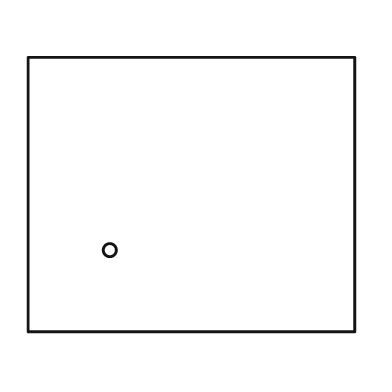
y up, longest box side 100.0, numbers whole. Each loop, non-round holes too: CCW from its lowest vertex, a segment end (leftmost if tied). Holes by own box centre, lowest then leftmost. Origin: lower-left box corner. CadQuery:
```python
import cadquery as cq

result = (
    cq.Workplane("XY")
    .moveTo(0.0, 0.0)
    .lineTo(100.0, 0.0)
    .lineTo(100.0, 84.0)
    .lineTo(0.0, 84.0)
    .close()
    .moveTo(25.0, 25.0)
    .circle(2.0)
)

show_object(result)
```